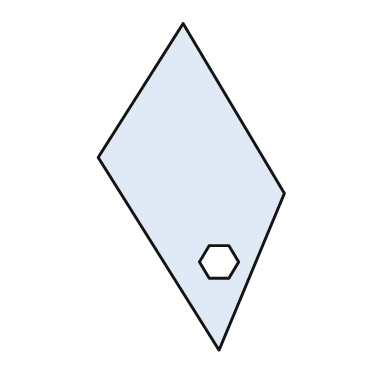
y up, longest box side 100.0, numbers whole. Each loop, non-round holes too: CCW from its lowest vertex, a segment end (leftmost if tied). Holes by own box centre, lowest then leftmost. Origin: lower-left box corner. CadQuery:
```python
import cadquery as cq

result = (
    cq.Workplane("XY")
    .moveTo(37.0, 0.0)
    .lineTo(57.0, 48.0)
    .lineTo(26.0, 100.0)
    .lineTo(0.0, 59.0)
    .close()
    .moveTo(34.0, 22.0)
    .lineTo(40.0, 22.0)
    .lineTo(43.0, 27.0)
    .lineTo(40.0, 32.0)
    .lineTo(34.0, 32.0)
    .lineTo(31.0, 27.0)
    .close()
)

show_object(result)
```